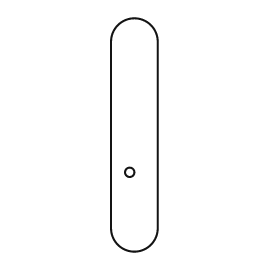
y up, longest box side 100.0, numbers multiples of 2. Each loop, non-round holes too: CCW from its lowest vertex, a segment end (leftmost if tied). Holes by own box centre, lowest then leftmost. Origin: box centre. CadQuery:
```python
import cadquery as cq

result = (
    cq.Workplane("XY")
    .moveTo(-10.0, -40.0)
    .threePointArc((0.0, -50.0), (10.0, -40.0))
    .lineTo(10.0, 40.0)
    .threePointArc((0.0, 50.0), (-10.0, 40.0))
    .close()
    .moveTo(-2.0, -16.0)
    .circle(2.0)
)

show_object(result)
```